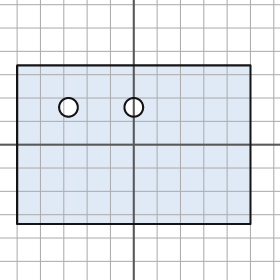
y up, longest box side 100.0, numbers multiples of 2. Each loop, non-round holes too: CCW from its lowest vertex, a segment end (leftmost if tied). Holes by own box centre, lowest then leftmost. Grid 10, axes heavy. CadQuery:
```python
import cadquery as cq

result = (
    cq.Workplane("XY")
    .moveTo(-50.0, -34.0)
    .lineTo(50.0, -34.0)
    .lineTo(50.0, 34.0)
    .lineTo(-50.0, 34.0)
    .close()
    .moveTo(-28.0, 16.0)
    .circle(4.0)
    .moveTo(0.0, 16.0)
    .circle(4.0)
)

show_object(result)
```